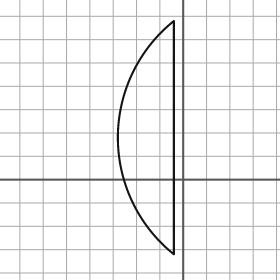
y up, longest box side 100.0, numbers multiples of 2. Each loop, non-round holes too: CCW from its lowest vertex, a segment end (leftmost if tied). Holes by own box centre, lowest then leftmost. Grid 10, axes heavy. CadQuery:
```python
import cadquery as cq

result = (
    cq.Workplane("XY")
    .moveTo(-4.0, -32.0)
    .lineTo(-4.0, 68.0)
    .threePointArc((-28.0, 18.0), (-4.0, -32.0))
    .close()
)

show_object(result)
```